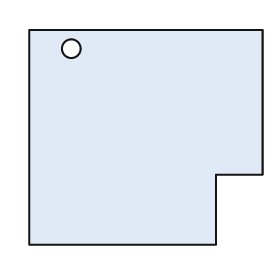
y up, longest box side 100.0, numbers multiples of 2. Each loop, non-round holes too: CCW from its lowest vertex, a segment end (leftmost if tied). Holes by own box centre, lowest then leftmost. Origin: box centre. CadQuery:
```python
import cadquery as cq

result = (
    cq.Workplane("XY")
    .moveTo(-50.0, -46.0)
    .lineTo(30.0, -46.0)
    .lineTo(30.0, -16.0)
    .lineTo(50.0, -16.0)
    .lineTo(50.0, 46.0)
    .lineTo(-50.0, 46.0)
    .close()
    .moveTo(-32.0, 38.0)
    .circle(4.0)
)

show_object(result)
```